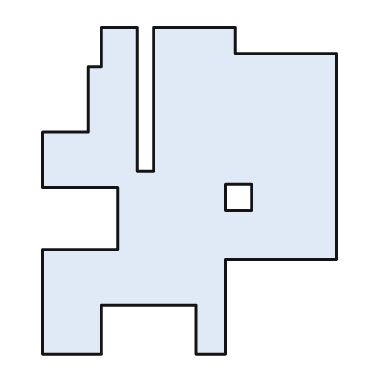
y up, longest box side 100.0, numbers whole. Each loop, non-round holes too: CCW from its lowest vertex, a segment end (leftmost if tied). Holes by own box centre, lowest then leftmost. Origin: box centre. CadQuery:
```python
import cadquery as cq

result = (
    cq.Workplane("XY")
    .moveTo(-45.0, -50.0)
    .lineTo(-27.0, -50.0)
    .lineTo(-27.0, -35.0)
    .lineTo(2.0, -35.0)
    .lineTo(2.0, -50.0)
    .lineTo(11.0, -50.0)
    .lineTo(11.0, -21.0)
    .lineTo(45.0, -21.0)
    .lineTo(45.0, 42.0)
    .lineTo(14.0, 42.0)
    .lineTo(14.0, 50.0)
    .lineTo(-11.0, 50.0)
    .lineTo(-11.0, 6.0)
    .lineTo(-16.0, 6.0)
    .lineTo(-16.0, 50.0)
    .lineTo(-27.0, 50.0)
    .lineTo(-27.0, 38.0)
    .lineTo(-31.0, 38.0)
    .lineTo(-31.0, 18.0)
    .lineTo(-45.0, 18.0)
    .lineTo(-45.0, 1.0)
    .lineTo(-22.0, 1.0)
    .lineTo(-22.0, -18.0)
    .lineTo(-45.0, -18.0)
    .close()
    .moveTo(11.0, -6.0)
    .lineTo(19.0, -6.0)
    .lineTo(19.0, 2.0)
    .lineTo(11.0, 2.0)
    .close()
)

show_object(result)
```